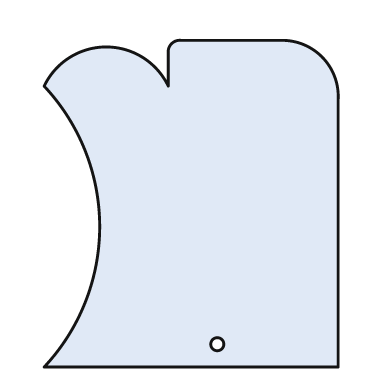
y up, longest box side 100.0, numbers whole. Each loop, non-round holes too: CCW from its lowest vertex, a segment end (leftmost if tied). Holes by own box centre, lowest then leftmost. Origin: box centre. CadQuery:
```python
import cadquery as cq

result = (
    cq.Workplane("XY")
    .moveTo(-45.0, -50.0)
    .lineTo(45.0, -50.0)
    .lineTo(45.0, 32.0)
    .threePointArc((40.0, 45.0), (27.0, 50.0))
    .lineTo(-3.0, 50.0)
    .threePointArc((-6.0, 49.0), (-7.0, 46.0))
    .lineTo(-7.0, 36.0)
    .threePointArc((-26.0, 48.0), (-45.0, 36.0))
    .threePointArc((-28.0, -7.0), (-45.0, -50.0))
    .close()
    .moveTo(8.0, -43.0)
    .circle(2.0)
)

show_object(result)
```